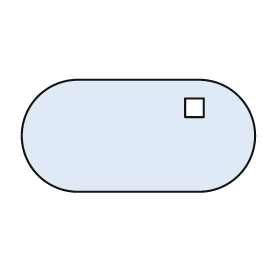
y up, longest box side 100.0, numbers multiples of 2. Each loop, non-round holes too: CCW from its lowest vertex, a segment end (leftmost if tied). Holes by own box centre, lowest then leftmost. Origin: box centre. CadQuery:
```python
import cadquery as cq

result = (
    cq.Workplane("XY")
    .moveTo(-26.0, -24.0)
    .lineTo(26.0, -24.0)
    .threePointArc((50.0, 0.0), (26.0, 24.0))
    .lineTo(-26.0, 24.0)
    .threePointArc((-50.0, 0.0), (-26.0, -24.0))
    .close()
    .moveTo(20.0, 8.0)
    .lineTo(28.0, 8.0)
    .lineTo(28.0, 16.0)
    .lineTo(20.0, 16.0)
    .close()
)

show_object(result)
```